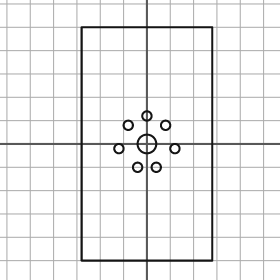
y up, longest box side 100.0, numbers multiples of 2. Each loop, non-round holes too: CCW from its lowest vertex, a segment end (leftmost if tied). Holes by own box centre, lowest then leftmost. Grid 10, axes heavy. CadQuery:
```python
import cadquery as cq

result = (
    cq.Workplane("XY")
    .moveTo(-28.0, -50.0)
    .lineTo(28.0, -50.0)
    .lineTo(28.0, 50.0)
    .lineTo(-28.0, 50.0)
    .close()
    .moveTo(-4.0, -10.0)
    .circle(2.0)
    .moveTo(4.0, -10.0)
    .circle(2.0)
    .moveTo(-12.0, -2.0)
    .circle(2.0)
    .moveTo(12.0, -2.0)
    .circle(2.0)
    .moveTo(0.0, 0.0)
    .circle(4.0)
    .moveTo(-8.0, 8.0)
    .circle(2.0)
    .moveTo(8.0, 8.0)
    .circle(2.0)
    .moveTo(0.0, 12.0)
    .circle(2.0)
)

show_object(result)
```